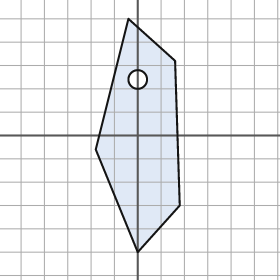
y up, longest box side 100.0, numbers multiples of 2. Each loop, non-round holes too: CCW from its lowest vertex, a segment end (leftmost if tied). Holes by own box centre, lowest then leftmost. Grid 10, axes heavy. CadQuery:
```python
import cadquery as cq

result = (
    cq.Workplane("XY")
    .moveTo(0.0, -50.0)
    .lineTo(18.0, -30.0)
    .lineTo(16.0, 32.0)
    .lineTo(-4.0, 50.0)
    .lineTo(-18.0, -6.0)
    .close()
    .moveTo(0.0, 24.0)
    .circle(4.0)
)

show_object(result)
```